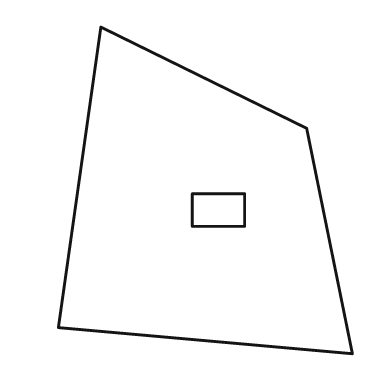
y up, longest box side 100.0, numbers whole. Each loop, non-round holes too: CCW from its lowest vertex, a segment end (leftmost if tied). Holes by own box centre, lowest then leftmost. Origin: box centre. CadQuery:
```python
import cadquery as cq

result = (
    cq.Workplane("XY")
    .moveTo(45.0, -50.0)
    .lineTo(31.0, 19.0)
    .lineTo(-32.0, 50.0)
    .lineTo(-45.0, -42.0)
    .close()
    .moveTo(-4.0, -11.0)
    .lineTo(12.0, -11.0)
    .lineTo(12.0, -1.0)
    .lineTo(-4.0, -1.0)
    .close()
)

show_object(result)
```